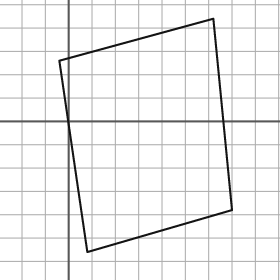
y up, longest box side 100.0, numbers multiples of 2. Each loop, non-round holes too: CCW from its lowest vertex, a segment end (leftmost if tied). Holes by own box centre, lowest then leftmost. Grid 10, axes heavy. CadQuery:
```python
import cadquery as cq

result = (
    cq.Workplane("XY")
    .moveTo(8.0, -56.0)
    .lineTo(70.0, -38.0)
    .lineTo(62.0, 44.0)
    .lineTo(-4.0, 26.0)
    .close()
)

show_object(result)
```